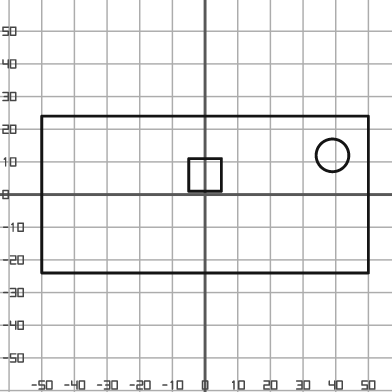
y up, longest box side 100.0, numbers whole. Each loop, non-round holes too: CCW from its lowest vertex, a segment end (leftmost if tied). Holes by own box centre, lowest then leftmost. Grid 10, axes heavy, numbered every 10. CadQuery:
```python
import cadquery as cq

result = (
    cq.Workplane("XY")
    .moveTo(-50.0, -24.0)
    .lineTo(50.0, -24.0)
    .lineTo(50.0, 24.0)
    .lineTo(-50.0, 24.0)
    .close()
    .moveTo(-5.0, 1.0)
    .lineTo(5.0, 1.0)
    .lineTo(5.0, 11.0)
    .lineTo(-5.0, 11.0)
    .close()
    .moveTo(39.0, 12.0)
    .circle(5.0)
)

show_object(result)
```